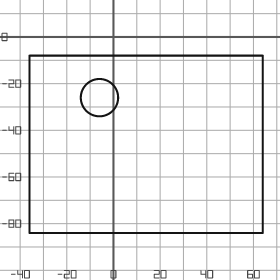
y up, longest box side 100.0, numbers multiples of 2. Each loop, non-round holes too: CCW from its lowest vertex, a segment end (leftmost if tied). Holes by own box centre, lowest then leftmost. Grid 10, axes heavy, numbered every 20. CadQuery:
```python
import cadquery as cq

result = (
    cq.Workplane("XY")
    .moveTo(-36.0, -84.0)
    .lineTo(64.0, -84.0)
    .lineTo(64.0, -8.0)
    .lineTo(-36.0, -8.0)
    .close()
    .moveTo(-6.0, -26.0)
    .circle(8.0)
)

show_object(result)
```